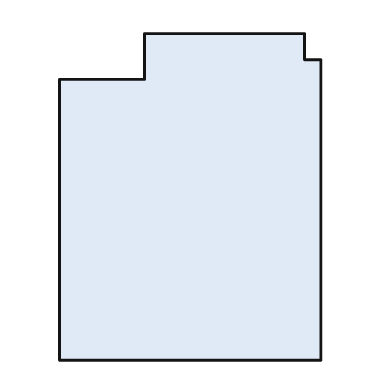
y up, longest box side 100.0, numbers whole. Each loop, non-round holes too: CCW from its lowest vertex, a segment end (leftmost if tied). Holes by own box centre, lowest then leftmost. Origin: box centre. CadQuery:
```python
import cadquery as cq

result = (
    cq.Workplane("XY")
    .moveTo(-40.0, -50.0)
    .lineTo(40.0, -50.0)
    .lineTo(40.0, 42.0)
    .lineTo(35.0, 42.0)
    .lineTo(35.0, 50.0)
    .lineTo(-14.0, 50.0)
    .lineTo(-14.0, 36.0)
    .lineTo(-40.0, 36.0)
    .close()
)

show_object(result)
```